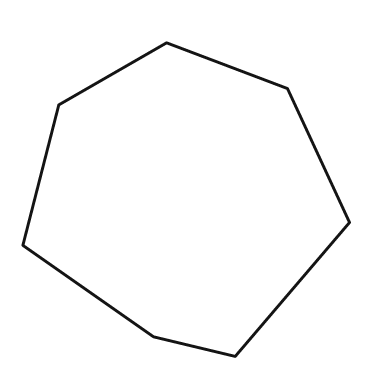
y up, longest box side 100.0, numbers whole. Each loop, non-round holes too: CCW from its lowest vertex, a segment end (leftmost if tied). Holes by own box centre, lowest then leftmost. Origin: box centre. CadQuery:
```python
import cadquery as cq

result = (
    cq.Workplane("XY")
    .moveTo(15.0, -48.0)
    .lineTo(50.0, -7.0)
    .lineTo(31.0, 34.0)
    .lineTo(-6.0, 48.0)
    .lineTo(-39.0, 29.0)
    .lineTo(-50.0, -14.0)
    .lineTo(-10.0, -42.0)
    .close()
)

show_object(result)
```